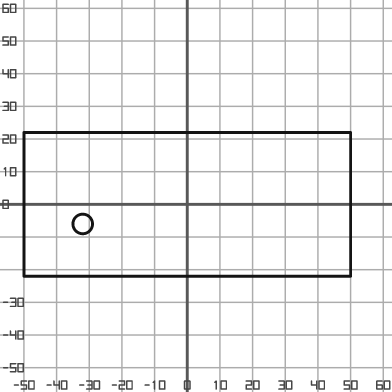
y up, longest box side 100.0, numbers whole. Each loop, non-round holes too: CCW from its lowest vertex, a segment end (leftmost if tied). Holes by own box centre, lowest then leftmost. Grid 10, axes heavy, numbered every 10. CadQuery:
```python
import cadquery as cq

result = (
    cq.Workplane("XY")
    .moveTo(-50.0, -22.0)
    .lineTo(50.0, -22.0)
    .lineTo(50.0, 22.0)
    .lineTo(-50.0, 22.0)
    .close()
    .moveTo(-32.0, -6.0)
    .circle(3.0)
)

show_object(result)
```